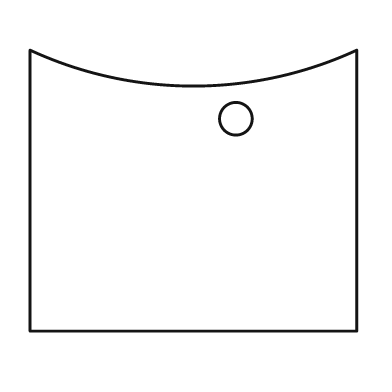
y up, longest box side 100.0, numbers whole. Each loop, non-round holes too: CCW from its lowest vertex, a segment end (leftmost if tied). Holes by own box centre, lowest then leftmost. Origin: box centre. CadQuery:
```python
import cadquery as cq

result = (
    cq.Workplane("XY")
    .moveTo(-50.0, -43.0)
    .lineTo(50.0, -43.0)
    .lineTo(50.0, 43.0)
    .threePointArc((0.0, 32.0), (-50.0, 43.0))
    .close()
    .moveTo(13.0, 22.0)
    .circle(5.0)
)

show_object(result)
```